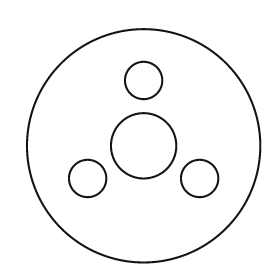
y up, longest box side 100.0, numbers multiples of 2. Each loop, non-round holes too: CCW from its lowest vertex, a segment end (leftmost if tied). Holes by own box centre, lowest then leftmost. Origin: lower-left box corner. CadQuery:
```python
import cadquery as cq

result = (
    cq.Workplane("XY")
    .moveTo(50.0, 50.0)
    .circle(50.0)
    .moveTo(26.0, 36.0)
    .circle(8.0)
    .moveTo(74.0, 36.0)
    .circle(8.0)
    .moveTo(50.0, 50.0)
    .circle(14.0)
    .moveTo(50.0, 78.0)
    .circle(8.0)
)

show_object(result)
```